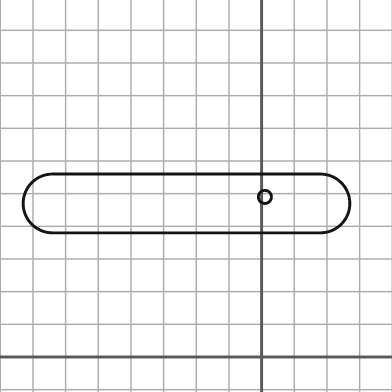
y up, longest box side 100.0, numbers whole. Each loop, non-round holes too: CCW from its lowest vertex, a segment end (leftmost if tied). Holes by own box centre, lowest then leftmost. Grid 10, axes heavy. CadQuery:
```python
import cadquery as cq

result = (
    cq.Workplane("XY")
    .moveTo(-64.0, 38.0)
    .lineTo(18.0, 38.0)
    .threePointArc((27.0, 47.0), (18.0, 56.0))
    .lineTo(-64.0, 56.0)
    .threePointArc((-73.0, 47.0), (-64.0, 38.0))
    .close()
    .moveTo(1.0, 49.0)
    .circle(2.0)
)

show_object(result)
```